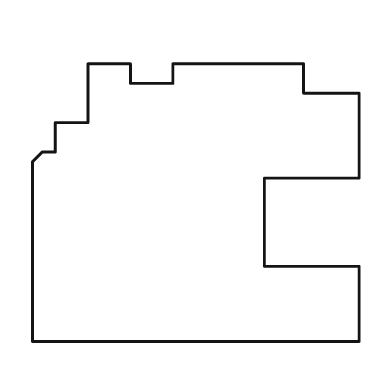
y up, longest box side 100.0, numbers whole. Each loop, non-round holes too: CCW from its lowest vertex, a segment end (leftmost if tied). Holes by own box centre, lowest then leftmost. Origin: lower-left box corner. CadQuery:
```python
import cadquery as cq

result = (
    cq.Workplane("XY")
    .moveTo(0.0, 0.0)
    .lineTo(100.0, 0.0)
    .lineTo(100.0, 23.0)
    .lineTo(71.0, 23.0)
    .lineTo(71.0, 50.0)
    .lineTo(100.0, 50.0)
    .lineTo(100.0, 76.0)
    .lineTo(83.0, 76.0)
    .lineTo(83.0, 85.0)
    .lineTo(43.0, 85.0)
    .lineTo(43.0, 79.0)
    .lineTo(30.0, 79.0)
    .lineTo(30.0, 85.0)
    .lineTo(17.0, 85.0)
    .lineTo(17.0, 67.0)
    .lineTo(7.0, 67.0)
    .lineTo(7.0, 58.0)
    .lineTo(3.0, 58.0)
    .lineTo(0.0, 55.0)
    .close()
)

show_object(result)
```